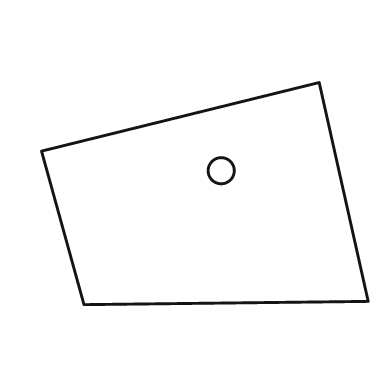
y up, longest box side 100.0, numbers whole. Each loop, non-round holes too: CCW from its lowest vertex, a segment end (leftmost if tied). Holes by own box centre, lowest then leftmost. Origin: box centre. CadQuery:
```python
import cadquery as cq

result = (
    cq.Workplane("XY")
    .moveTo(-37.0, -34.0)
    .lineTo(50.0, -33.0)
    .lineTo(35.0, 34.0)
    .lineTo(-50.0, 13.0)
    .close()
    .moveTo(5.0, 7.0)
    .circle(4.0)
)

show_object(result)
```